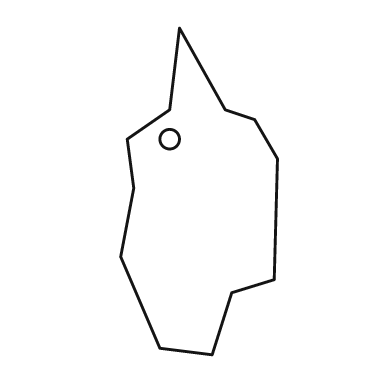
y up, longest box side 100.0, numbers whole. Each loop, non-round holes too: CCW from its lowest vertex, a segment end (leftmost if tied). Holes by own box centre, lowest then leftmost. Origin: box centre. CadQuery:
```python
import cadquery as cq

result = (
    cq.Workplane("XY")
    .moveTo(4.0, -50.0)
    .lineTo(10.0, -31.0)
    .lineTo(23.0, -27.0)
    .lineTo(24.0, 10.0)
    .lineTo(17.0, 22.0)
    .lineTo(8.0, 25.0)
    .lineTo(-6.0, 50.0)
    .lineTo(-9.0, 25.0)
    .lineTo(-22.0, 16.0)
    .lineTo(-20.0, 1.0)
    .lineTo(-24.0, -20.0)
    .lineTo(-12.0, -48.0)
    .close()
    .moveTo(-9.0, 16.0)
    .circle(3.0)
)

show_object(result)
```